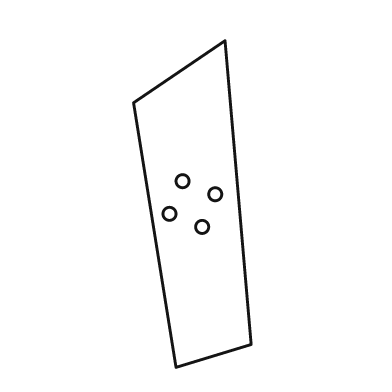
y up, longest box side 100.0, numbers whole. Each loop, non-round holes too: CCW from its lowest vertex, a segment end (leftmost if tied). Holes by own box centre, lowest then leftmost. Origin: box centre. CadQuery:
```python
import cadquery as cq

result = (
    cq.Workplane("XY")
    .moveTo(-5.0, -50.0)
    .lineTo(18.0, -43.0)
    .lineTo(10.0, 50.0)
    .lineTo(-18.0, 31.0)
    .close()
    .moveTo(3.0, -7.0)
    .circle(2.0)
    .moveTo(-7.0, -3.0)
    .circle(2.0)
    .moveTo(7.0, 3.0)
    .circle(2.0)
    .moveTo(-3.0, 7.0)
    .circle(2.0)
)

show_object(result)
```